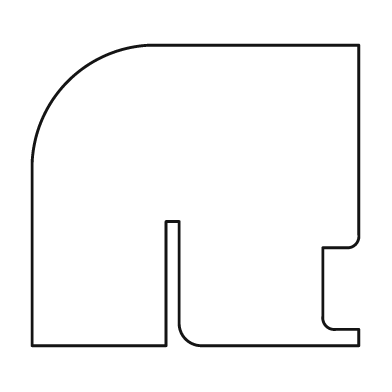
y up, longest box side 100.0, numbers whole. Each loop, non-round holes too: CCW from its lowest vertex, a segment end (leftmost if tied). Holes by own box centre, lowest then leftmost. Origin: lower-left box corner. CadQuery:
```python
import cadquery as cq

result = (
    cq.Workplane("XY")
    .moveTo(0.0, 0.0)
    .lineTo(41.0, 0.0)
    .lineTo(41.0, 38.0)
    .lineTo(45.0, 38.0)
    .lineTo(45.0, 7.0)
    .threePointArc((47.0, 2.0), (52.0, 0.0))
    .lineTo(100.0, 0.0)
    .lineTo(100.0, 5.0)
    .lineTo(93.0, 5.0)
    .threePointArc((90.0, 6.0), (89.0, 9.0))
    .lineTo(89.0, 30.0)
    .lineTo(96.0, 30.0)
    .threePointArc((99.0, 31.0), (100.0, 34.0))
    .lineTo(100.0, 92.0)
    .lineTo(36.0, 92.0)
    .threePointArc((11.0, 81.0), (0.0, 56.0))
    .close()
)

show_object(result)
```